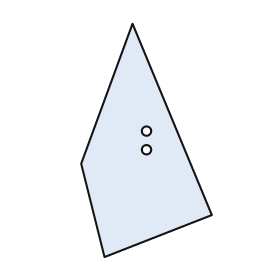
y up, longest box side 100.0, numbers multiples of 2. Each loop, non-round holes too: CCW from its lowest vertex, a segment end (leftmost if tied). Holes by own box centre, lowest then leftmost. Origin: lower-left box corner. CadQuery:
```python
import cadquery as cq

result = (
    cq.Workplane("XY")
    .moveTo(10.0, 0.0)
    .lineTo(56.0, 18.0)
    .lineTo(22.0, 100.0)
    .lineTo(0.0, 40.0)
    .close()
    .moveTo(28.0, 46.0)
    .circle(2.0)
    .moveTo(28.0, 54.0)
    .circle(2.0)
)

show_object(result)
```